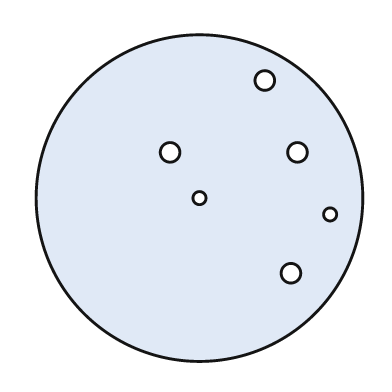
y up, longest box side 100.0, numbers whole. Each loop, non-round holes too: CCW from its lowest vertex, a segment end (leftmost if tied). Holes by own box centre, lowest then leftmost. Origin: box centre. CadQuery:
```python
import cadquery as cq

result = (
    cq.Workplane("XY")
    .moveTo(0.0, 0.0)
    .circle(50.0)
    .moveTo(28.0, -23.0)
    .circle(3.0)
    .moveTo(40.0, -5.0)
    .circle(2.0)
    .moveTo(0.0, 0.0)
    .circle(2.0)
    .moveTo(-9.0, 14.0)
    .circle(3.0)
    .moveTo(30.0, 14.0)
    .circle(3.0)
    .moveTo(20.0, 36.0)
    .circle(3.0)
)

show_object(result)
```